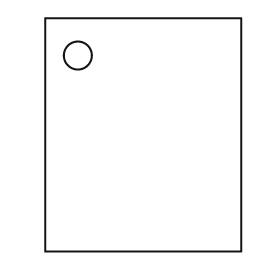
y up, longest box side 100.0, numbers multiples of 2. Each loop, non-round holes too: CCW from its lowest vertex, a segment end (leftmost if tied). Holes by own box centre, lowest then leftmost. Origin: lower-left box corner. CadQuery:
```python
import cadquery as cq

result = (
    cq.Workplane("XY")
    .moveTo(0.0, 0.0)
    .lineTo(84.0, 0.0)
    .lineTo(84.0, 100.0)
    .lineTo(0.0, 100.0)
    .close()
    .moveTo(14.0, 84.0)
    .circle(6.0)
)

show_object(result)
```